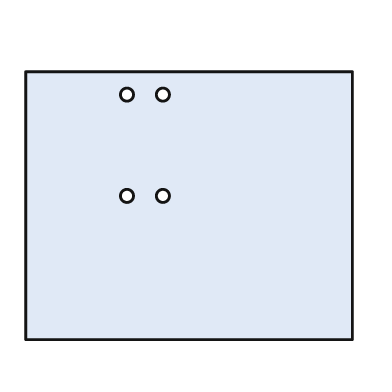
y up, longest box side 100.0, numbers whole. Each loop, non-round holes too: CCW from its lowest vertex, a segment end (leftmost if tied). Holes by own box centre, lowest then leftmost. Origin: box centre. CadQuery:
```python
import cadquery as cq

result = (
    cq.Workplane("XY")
    .moveTo(-50.0, -41.0)
    .lineTo(50.0, -41.0)
    .lineTo(50.0, 41.0)
    .lineTo(-50.0, 41.0)
    .close()
    .moveTo(-19.0, 3.0)
    .circle(2.0)
    .moveTo(-8.0, 3.0)
    .circle(2.0)
    .moveTo(-19.0, 34.0)
    .circle(2.0)
    .moveTo(-8.0, 34.0)
    .circle(2.0)
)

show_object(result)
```